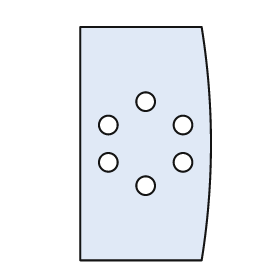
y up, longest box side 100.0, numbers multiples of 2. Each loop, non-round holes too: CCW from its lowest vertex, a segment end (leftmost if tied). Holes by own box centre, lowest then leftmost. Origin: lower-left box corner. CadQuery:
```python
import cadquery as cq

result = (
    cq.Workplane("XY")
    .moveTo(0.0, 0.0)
    .lineTo(52.0, 0.0)
    .threePointArc((56.0, 50.0), (52.0, 100.0))
    .lineTo(0.0, 100.0)
    .close()
    .moveTo(28.0, 32.0)
    .circle(4.0)
    .moveTo(12.0, 42.0)
    .circle(4.0)
    .moveTo(44.0, 42.0)
    .circle(4.0)
    .moveTo(12.0, 58.0)
    .circle(4.0)
    .moveTo(44.0, 58.0)
    .circle(4.0)
    .moveTo(28.0, 68.0)
    .circle(4.0)
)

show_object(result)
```